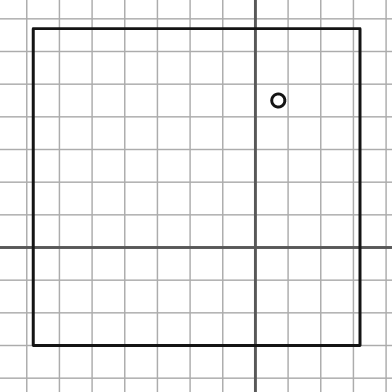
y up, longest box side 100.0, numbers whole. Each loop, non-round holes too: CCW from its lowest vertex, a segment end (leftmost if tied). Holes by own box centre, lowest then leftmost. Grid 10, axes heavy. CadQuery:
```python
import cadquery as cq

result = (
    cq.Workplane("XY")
    .moveTo(-68.0, -30.0)
    .lineTo(32.0, -30.0)
    .lineTo(32.0, 67.0)
    .lineTo(-68.0, 67.0)
    .close()
    .moveTo(7.0, 45.0)
    .circle(2.0)
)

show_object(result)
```